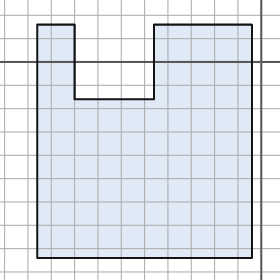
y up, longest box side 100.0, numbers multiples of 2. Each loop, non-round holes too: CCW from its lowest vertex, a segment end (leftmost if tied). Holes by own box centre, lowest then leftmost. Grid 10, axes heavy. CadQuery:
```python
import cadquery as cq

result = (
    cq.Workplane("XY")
    .moveTo(-96.0, -84.0)
    .lineTo(-4.0, -84.0)
    .lineTo(-4.0, 16.0)
    .lineTo(-46.0, 16.0)
    .lineTo(-46.0, -16.0)
    .lineTo(-80.0, -16.0)
    .lineTo(-80.0, 16.0)
    .lineTo(-96.0, 16.0)
    .close()
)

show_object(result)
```